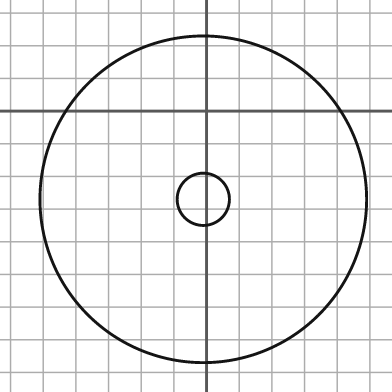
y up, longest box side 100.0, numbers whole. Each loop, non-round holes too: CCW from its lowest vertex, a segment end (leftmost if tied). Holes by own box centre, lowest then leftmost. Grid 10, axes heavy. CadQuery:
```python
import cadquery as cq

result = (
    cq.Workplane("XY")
    .moveTo(-1.0, -27.0)
    .circle(50.0)
    .moveTo(-1.0, -27.0)
    .circle(8.0)
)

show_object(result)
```